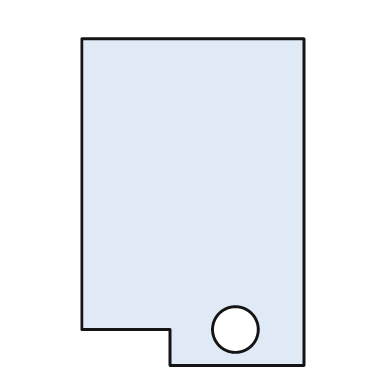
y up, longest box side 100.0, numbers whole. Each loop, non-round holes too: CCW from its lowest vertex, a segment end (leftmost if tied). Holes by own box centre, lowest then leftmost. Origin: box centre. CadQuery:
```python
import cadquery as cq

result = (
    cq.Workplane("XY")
    .moveTo(-7.0, -50.0)
    .lineTo(34.0, -50.0)
    .lineTo(34.0, 50.0)
    .lineTo(-34.0, 50.0)
    .lineTo(-34.0, -39.0)
    .lineTo(-7.0, -39.0)
    .close()
    .moveTo(13.0, -39.0)
    .circle(7.0)
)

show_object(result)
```